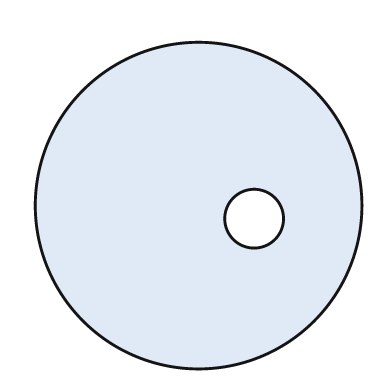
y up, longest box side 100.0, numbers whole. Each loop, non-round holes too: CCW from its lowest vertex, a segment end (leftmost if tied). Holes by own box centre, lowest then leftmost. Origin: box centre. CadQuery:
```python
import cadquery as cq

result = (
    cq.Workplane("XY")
    .moveTo(0.0, 0.0)
    .circle(50.0)
    .moveTo(17.0, -4.0)
    .circle(9.0)
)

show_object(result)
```